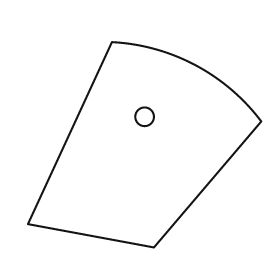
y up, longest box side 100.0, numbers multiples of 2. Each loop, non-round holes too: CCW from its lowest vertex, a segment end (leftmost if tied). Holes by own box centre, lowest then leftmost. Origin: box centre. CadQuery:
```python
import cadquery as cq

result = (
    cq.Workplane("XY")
    .moveTo(4.0, -44.0)
    .lineTo(50.0, 10.0)
    .threePointArc((22.0, 34.0), (-14.0, 44.0))
    .lineTo(-50.0, -34.0)
    .close()
    .moveTo(0.0, 12.0)
    .circle(4.0)
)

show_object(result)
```